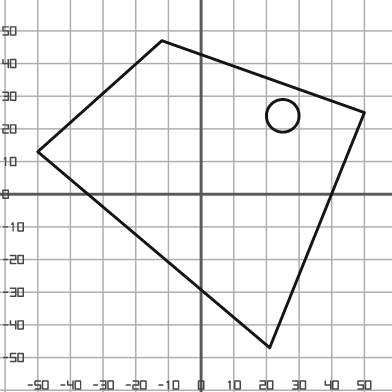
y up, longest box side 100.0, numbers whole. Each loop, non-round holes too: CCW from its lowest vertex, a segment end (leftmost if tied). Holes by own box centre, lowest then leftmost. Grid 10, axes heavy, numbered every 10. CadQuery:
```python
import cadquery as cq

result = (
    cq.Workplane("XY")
    .moveTo(21.0, -47.0)
    .lineTo(50.0, 25.0)
    .lineTo(-12.0, 47.0)
    .lineTo(-50.0, 13.0)
    .close()
    .moveTo(25.0, 24.0)
    .circle(5.0)
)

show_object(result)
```